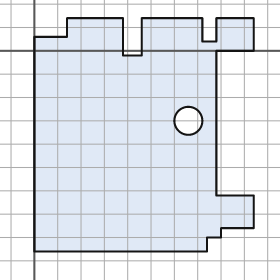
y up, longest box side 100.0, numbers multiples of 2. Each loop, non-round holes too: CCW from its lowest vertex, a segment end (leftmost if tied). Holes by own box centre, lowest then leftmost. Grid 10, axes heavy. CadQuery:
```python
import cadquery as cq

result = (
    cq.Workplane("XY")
    .moveTo(0.0, -86.0)
    .lineTo(74.0, -86.0)
    .lineTo(74.0, -80.0)
    .lineTo(80.0, -80.0)
    .lineTo(80.0, -76.0)
    .lineTo(94.0, -76.0)
    .lineTo(94.0, -62.0)
    .lineTo(78.0, -62.0)
    .lineTo(78.0, 0.0)
    .lineTo(94.0, 0.0)
    .lineTo(94.0, 14.0)
    .lineTo(78.0, 14.0)
    .lineTo(78.0, 4.0)
    .lineTo(72.0, 4.0)
    .lineTo(72.0, 14.0)
    .lineTo(46.0, 14.0)
    .lineTo(46.0, -2.0)
    .lineTo(38.0, -2.0)
    .lineTo(38.0, 14.0)
    .lineTo(14.0, 14.0)
    .lineTo(14.0, 6.0)
    .lineTo(0.0, 6.0)
    .close()
    .moveTo(66.0, -30.0)
    .circle(6.0)
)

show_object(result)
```